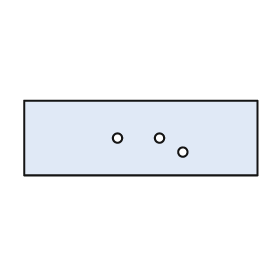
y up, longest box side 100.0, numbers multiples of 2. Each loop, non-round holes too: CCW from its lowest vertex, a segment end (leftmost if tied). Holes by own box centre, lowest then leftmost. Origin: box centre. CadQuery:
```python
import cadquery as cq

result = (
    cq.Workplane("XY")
    .moveTo(-50.0, -16.0)
    .lineTo(50.0, -16.0)
    .lineTo(50.0, 16.0)
    .lineTo(-50.0, 16.0)
    .close()
    .moveTo(18.0, -6.0)
    .circle(2.0)
    .moveTo(-10.0, 0.0)
    .circle(2.0)
    .moveTo(8.0, 0.0)
    .circle(2.0)
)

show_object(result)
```